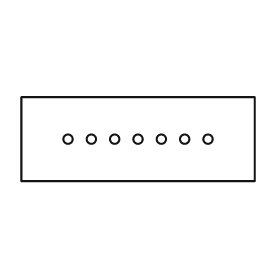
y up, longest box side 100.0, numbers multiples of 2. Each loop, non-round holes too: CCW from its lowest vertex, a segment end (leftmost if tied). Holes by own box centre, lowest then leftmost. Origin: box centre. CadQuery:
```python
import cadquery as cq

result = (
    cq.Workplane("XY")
    .moveTo(-50.0, -18.0)
    .lineTo(50.0, -18.0)
    .lineTo(50.0, 18.0)
    .lineTo(-50.0, 18.0)
    .close()
    .moveTo(-30.0, 0.0)
    .circle(2.0)
    .moveTo(-20.0, 0.0)
    .circle(2.0)
    .moveTo(-10.0, 0.0)
    .circle(2.0)
    .moveTo(0.0, 0.0)
    .circle(2.0)
    .moveTo(10.0, 0.0)
    .circle(2.0)
    .moveTo(20.0, 0.0)
    .circle(2.0)
    .moveTo(30.0, 0.0)
    .circle(2.0)
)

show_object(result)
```